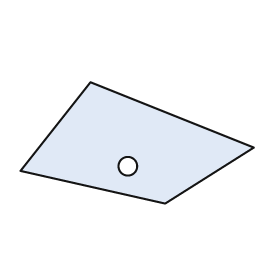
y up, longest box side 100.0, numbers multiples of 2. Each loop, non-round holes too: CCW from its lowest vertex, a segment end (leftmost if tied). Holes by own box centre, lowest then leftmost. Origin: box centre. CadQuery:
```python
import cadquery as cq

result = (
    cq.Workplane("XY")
    .moveTo(12.0, -26.0)
    .lineTo(50.0, -2.0)
    .lineTo(-20.0, 26.0)
    .lineTo(-50.0, -12.0)
    .close()
    .moveTo(-4.0, -10.0)
    .circle(4.0)
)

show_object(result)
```